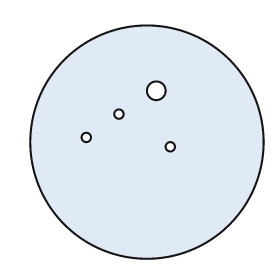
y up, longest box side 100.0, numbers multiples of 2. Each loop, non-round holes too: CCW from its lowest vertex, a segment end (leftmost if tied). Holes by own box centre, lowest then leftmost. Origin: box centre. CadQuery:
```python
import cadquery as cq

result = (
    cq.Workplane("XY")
    .moveTo(0.0, 0.0)
    .circle(50.0)
    .moveTo(10.0, -2.0)
    .circle(2.0)
    .moveTo(-26.0, 2.0)
    .circle(2.0)
    .moveTo(-12.0, 12.0)
    .circle(2.0)
    .moveTo(4.0, 22.0)
    .circle(4.0)
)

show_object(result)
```